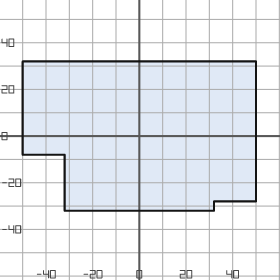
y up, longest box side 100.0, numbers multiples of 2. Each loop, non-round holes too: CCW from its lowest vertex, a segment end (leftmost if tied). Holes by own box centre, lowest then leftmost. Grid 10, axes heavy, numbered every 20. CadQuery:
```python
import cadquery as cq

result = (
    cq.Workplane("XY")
    .moveTo(-32.0, -32.0)
    .lineTo(32.0, -32.0)
    .lineTo(32.0, -28.0)
    .lineTo(50.0, -28.0)
    .lineTo(50.0, 32.0)
    .lineTo(-50.0, 32.0)
    .lineTo(-50.0, -8.0)
    .lineTo(-32.0, -8.0)
    .close()
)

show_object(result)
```